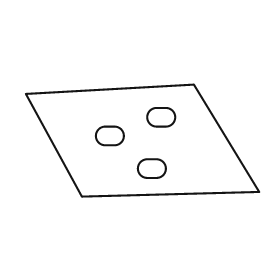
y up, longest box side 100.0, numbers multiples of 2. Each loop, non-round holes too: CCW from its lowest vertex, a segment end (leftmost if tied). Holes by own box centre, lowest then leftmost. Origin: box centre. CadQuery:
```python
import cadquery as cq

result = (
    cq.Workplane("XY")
    .moveTo(-26.0, -24.0)
    .lineTo(50.0, -22.0)
    .lineTo(22.0, 24.0)
    .lineTo(-50.0, 20.0)
    .close()
    .moveTo(2.0, -16.0)
    .lineTo(6.0, -16.0)
    .threePointArc((10.0, -12.0), (6.0, -8.0))
    .lineTo(2.0, -8.0)
    .threePointArc((-2.0, -12.0), (2.0, -16.0))
    .close()
    .moveTo(-16.0, -2.0)
    .lineTo(-12.0, -2.0)
    .threePointArc((-8.0, 2.0), (-12.0, 6.0))
    .lineTo(-16.0, 6.0)
    .threePointArc((-20.0, 2.0), (-16.0, -2.0))
    .close()
    .moveTo(6.0, 6.0)
    .lineTo(10.0, 6.0)
    .threePointArc((14.0, 10.0), (10.0, 14.0))
    .lineTo(6.0, 14.0)
    .threePointArc((2.0, 10.0), (6.0, 6.0))
    .close()
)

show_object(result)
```